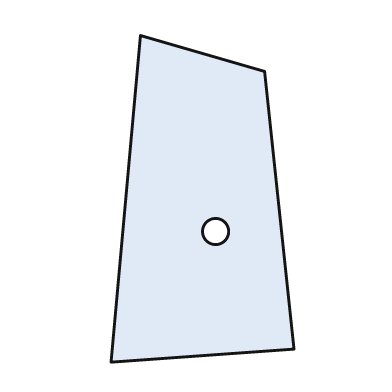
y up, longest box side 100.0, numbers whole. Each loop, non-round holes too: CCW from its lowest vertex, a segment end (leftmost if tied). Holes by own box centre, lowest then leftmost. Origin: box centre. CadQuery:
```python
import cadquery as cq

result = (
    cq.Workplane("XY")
    .moveTo(-28.0, -50.0)
    .lineTo(28.0, -46.0)
    .lineTo(19.0, 39.0)
    .lineTo(-19.0, 50.0)
    .close()
    .moveTo(4.0, -10.0)
    .circle(4.0)
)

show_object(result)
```